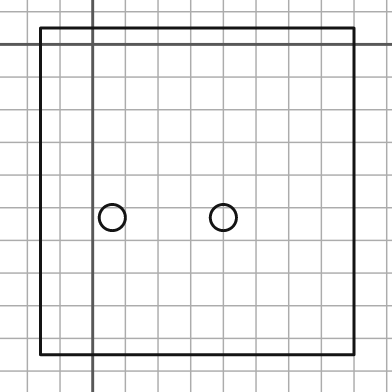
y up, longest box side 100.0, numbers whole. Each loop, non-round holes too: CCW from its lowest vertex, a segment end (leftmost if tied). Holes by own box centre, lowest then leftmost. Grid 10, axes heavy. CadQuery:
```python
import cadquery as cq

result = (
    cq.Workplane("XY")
    .moveTo(-16.0, -95.0)
    .lineTo(80.0, -95.0)
    .lineTo(80.0, 5.0)
    .lineTo(-16.0, 5.0)
    .close()
    .moveTo(6.0, -53.0)
    .circle(4.0)
    .moveTo(40.0, -53.0)
    .circle(4.0)
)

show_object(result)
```